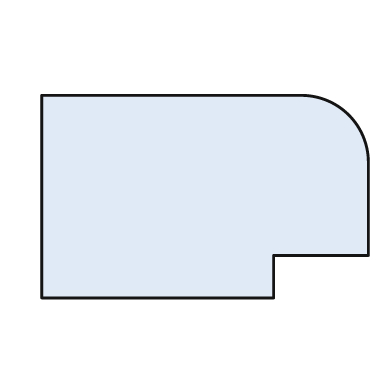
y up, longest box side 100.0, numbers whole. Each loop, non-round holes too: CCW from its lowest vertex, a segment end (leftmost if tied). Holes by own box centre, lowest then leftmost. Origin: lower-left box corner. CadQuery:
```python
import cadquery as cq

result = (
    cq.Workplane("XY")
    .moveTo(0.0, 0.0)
    .lineTo(71.0, 0.0)
    .lineTo(71.0, 13.0)
    .lineTo(100.0, 13.0)
    .lineTo(100.0, 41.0)
    .threePointArc((94.0, 56.0), (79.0, 62.0))
    .lineTo(0.0, 62.0)
    .close()
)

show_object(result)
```